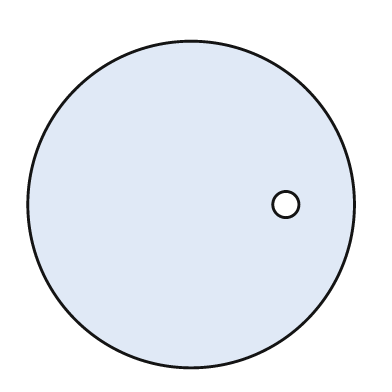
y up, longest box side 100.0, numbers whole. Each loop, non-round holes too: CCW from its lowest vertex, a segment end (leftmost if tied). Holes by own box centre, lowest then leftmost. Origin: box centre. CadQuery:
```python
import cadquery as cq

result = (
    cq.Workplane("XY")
    .moveTo(0.0, 0.0)
    .circle(50.0)
    .moveTo(29.0, 0.0)
    .circle(4.0)
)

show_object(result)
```